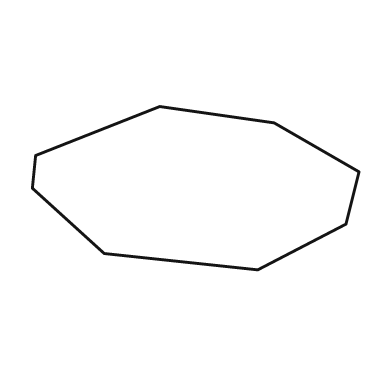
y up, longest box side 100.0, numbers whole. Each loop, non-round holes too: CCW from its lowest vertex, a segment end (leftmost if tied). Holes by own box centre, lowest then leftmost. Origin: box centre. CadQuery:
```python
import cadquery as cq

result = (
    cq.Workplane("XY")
    .moveTo(19.0, -25.0)
    .lineTo(46.0, -11.0)
    .lineTo(50.0, 5.0)
    .lineTo(24.0, 20.0)
    .lineTo(-11.0, 25.0)
    .lineTo(-49.0, 10.0)
    .lineTo(-50.0, 0.0)
    .lineTo(-28.0, -20.0)
    .close()
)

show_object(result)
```